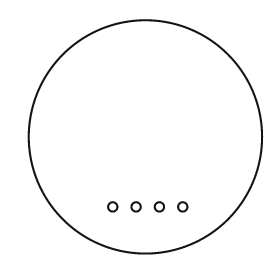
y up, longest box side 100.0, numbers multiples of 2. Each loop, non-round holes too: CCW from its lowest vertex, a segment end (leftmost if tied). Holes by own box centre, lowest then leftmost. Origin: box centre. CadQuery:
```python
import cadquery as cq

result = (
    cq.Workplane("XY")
    .moveTo(0.0, 0.0)
    .circle(50.0)
    .moveTo(-14.0, -30.0)
    .circle(2.0)
    .moveTo(-4.0, -30.0)
    .circle(2.0)
    .moveTo(6.0, -30.0)
    .circle(2.0)
    .moveTo(16.0, -30.0)
    .circle(2.0)
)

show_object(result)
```